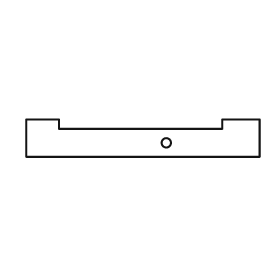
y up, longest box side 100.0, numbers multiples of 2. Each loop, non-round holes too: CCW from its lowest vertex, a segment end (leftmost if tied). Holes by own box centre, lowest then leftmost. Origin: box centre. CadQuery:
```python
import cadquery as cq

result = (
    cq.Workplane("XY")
    .moveTo(-50.0, -8.0)
    .lineTo(50.0, -8.0)
    .lineTo(50.0, 8.0)
    .lineTo(34.0, 8.0)
    .lineTo(34.0, 4.0)
    .lineTo(-36.0, 4.0)
    .lineTo(-36.0, 8.0)
    .lineTo(-50.0, 8.0)
    .close()
    .moveTo(10.0, -2.0)
    .circle(2.0)
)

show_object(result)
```